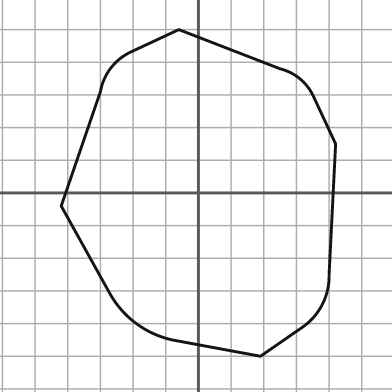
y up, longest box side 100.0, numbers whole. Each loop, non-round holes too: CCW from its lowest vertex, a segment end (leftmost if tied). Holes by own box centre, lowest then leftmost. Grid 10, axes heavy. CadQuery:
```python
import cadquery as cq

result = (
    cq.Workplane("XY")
    .moveTo(19.0, -50.0)
    .lineTo(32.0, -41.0)
    .threePointArc((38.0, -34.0), (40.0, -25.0))
    .lineTo(42.0, 15.0)
    .lineTo(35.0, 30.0)
    .threePointArc((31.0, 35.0), (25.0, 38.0))
    .lineTo(-6.0, 50.0)
    .lineTo(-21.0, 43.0)
    .threePointArc((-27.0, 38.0), (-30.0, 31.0))
    .lineTo(-42.0, -4.0)
    .lineTo(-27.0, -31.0)
    .threePointArc((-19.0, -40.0), (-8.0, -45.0))
    .close()
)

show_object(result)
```